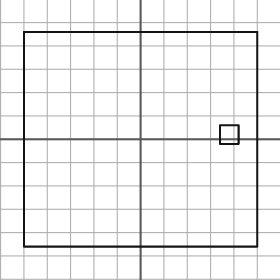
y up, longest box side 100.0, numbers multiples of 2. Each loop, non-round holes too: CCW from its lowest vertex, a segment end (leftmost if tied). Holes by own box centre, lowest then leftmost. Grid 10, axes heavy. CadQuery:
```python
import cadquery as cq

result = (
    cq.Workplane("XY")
    .moveTo(-50.0, -46.0)
    .lineTo(50.0, -46.0)
    .lineTo(50.0, 46.0)
    .lineTo(-50.0, 46.0)
    .close()
    .moveTo(34.0, -2.0)
    .lineTo(42.0, -2.0)
    .lineTo(42.0, 6.0)
    .lineTo(34.0, 6.0)
    .close()
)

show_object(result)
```